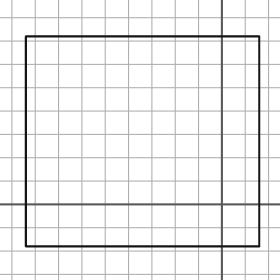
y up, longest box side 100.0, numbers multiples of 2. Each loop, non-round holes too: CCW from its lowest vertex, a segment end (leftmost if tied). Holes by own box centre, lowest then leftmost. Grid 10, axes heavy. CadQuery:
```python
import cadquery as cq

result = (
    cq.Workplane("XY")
    .moveTo(-84.0, -18.0)
    .lineTo(16.0, -18.0)
    .lineTo(16.0, 72.0)
    .lineTo(-84.0, 72.0)
    .close()
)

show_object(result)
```